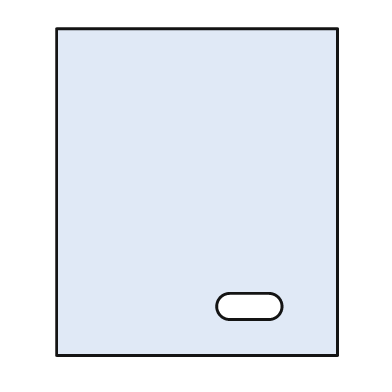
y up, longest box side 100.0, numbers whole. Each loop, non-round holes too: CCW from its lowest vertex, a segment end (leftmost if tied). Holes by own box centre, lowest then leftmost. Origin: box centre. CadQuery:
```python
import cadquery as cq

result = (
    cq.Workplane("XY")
    .moveTo(-43.0, -50.0)
    .lineTo(43.0, -50.0)
    .lineTo(43.0, 50.0)
    .lineTo(-43.0, 50.0)
    .close()
    .moveTo(10.0, -39.0)
    .lineTo(22.0, -39.0)
    .threePointArc((26.0, -35.0), (22.0, -31.0))
    .lineTo(10.0, -31.0)
    .threePointArc((6.0, -35.0), (10.0, -39.0))
    .close()
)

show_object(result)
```